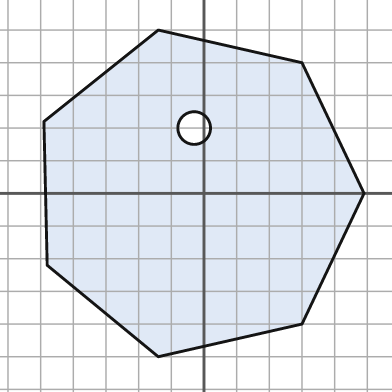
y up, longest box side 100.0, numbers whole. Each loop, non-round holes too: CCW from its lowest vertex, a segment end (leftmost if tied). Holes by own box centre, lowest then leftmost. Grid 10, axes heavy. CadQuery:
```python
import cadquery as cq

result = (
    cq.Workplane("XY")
    .moveTo(-14.0, -50.0)
    .lineTo(30.0, -40.0)
    .lineTo(49.0, 0.0)
    .lineTo(30.0, 40.0)
    .lineTo(-14.0, 50.0)
    .lineTo(-49.0, 22.0)
    .lineTo(-48.0, -22.0)
    .close()
    .moveTo(-3.0, 20.0)
    .circle(5.0)
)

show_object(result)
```